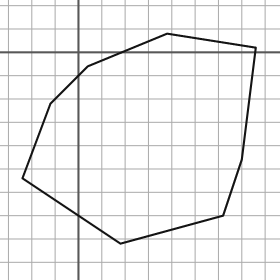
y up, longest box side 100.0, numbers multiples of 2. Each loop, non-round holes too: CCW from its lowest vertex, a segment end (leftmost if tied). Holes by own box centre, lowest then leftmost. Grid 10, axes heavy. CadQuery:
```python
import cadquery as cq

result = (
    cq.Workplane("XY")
    .moveTo(18.0, -82.0)
    .lineTo(62.0, -70.0)
    .lineTo(70.0, -46.0)
    .lineTo(76.0, 2.0)
    .lineTo(38.0, 8.0)
    .lineTo(4.0, -6.0)
    .lineTo(-12.0, -22.0)
    .lineTo(-24.0, -54.0)
    .close()
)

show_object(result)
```